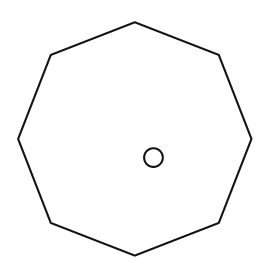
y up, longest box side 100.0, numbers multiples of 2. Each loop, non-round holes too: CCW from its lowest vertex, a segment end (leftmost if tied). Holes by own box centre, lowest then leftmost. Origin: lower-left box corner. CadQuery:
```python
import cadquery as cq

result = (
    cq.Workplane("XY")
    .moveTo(50.0, 0.0)
    .lineTo(86.0, 14.0)
    .lineTo(100.0, 50.0)
    .lineTo(86.0, 86.0)
    .lineTo(50.0, 100.0)
    .lineTo(14.0, 86.0)
    .lineTo(0.0, 50.0)
    .lineTo(14.0, 14.0)
    .close()
    .moveTo(58.0, 42.0)
    .circle(4.0)
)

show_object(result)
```